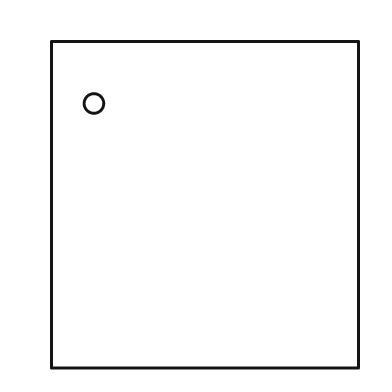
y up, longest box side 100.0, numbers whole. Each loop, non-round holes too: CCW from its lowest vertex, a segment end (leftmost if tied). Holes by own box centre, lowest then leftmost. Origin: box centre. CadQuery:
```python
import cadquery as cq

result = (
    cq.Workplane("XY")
    .moveTo(-47.0, -50.0)
    .lineTo(47.0, -50.0)
    .lineTo(47.0, 50.0)
    .lineTo(-47.0, 50.0)
    .close()
    .moveTo(-34.0, 31.0)
    .circle(3.0)
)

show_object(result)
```